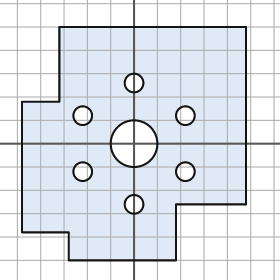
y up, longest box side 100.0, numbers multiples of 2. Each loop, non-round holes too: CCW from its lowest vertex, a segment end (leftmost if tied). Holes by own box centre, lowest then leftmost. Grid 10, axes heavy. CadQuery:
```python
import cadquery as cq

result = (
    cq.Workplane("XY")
    .moveTo(-28.0, -50.0)
    .lineTo(18.0, -50.0)
    .lineTo(18.0, -26.0)
    .lineTo(48.0, -26.0)
    .lineTo(48.0, 50.0)
    .lineTo(-32.0, 50.0)
    .lineTo(-32.0, 18.0)
    .lineTo(-48.0, 18.0)
    .lineTo(-48.0, -38.0)
    .lineTo(-28.0, -38.0)
    .close()
    .moveTo(0.0, -26.0)
    .circle(4.0)
    .moveTo(-22.0, -12.0)
    .circle(4.0)
    .moveTo(22.0, -12.0)
    .circle(4.0)
    .moveTo(0.0, 0.0)
    .circle(10.0)
    .moveTo(-22.0, 12.0)
    .circle(4.0)
    .moveTo(22.0, 12.0)
    .circle(4.0)
    .moveTo(0.0, 26.0)
    .circle(4.0)
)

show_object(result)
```